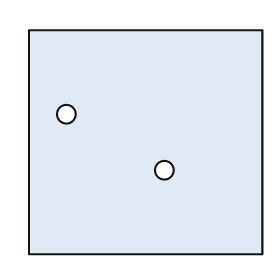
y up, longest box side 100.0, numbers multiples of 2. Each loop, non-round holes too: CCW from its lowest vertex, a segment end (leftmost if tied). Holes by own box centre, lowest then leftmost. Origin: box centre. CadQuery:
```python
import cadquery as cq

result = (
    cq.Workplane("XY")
    .moveTo(-50.0, -48.0)
    .lineTo(50.0, -48.0)
    .lineTo(50.0, 48.0)
    .lineTo(-50.0, 48.0)
    .close()
    .moveTo(8.0, -12.0)
    .circle(4.0)
    .moveTo(-34.0, 12.0)
    .circle(4.0)
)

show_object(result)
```